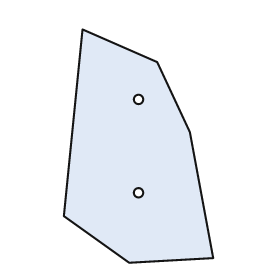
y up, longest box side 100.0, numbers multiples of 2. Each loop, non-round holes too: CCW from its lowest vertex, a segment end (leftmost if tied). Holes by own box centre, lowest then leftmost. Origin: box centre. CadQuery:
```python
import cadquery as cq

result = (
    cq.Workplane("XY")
    .moveTo(-4.0, -50.0)
    .lineTo(32.0, -48.0)
    .lineTo(22.0, 6.0)
    .lineTo(8.0, 36.0)
    .lineTo(-24.0, 50.0)
    .lineTo(-32.0, -30.0)
    .close()
    .moveTo(0.0, -20.0)
    .circle(2.0)
    .moveTo(0.0, 20.0)
    .circle(2.0)
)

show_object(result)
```